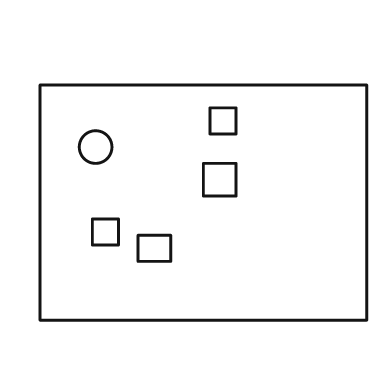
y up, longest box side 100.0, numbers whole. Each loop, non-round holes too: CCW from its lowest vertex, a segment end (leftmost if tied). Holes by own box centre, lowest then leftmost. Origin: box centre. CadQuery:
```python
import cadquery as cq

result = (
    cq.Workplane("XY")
    .moveTo(-50.0, -36.0)
    .lineTo(50.0, -36.0)
    .lineTo(50.0, 36.0)
    .lineTo(-50.0, 36.0)
    .close()
    .moveTo(-20.0, -18.0)
    .lineTo(-10.0, -18.0)
    .lineTo(-10.0, -10.0)
    .lineTo(-20.0, -10.0)
    .close()
    .moveTo(-34.0, -13.0)
    .lineTo(-26.0, -13.0)
    .lineTo(-26.0, -5.0)
    .lineTo(-34.0, -5.0)
    .close()
    .moveTo(0.0, 2.0)
    .lineTo(10.0, 2.0)
    .lineTo(10.0, 12.0)
    .lineTo(0.0, 12.0)
    .close()
    .moveTo(-33.0, 17.0)
    .circle(5.0)
    .moveTo(2.0, 21.0)
    .lineTo(10.0, 21.0)
    .lineTo(10.0, 29.0)
    .lineTo(2.0, 29.0)
    .close()
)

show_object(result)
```